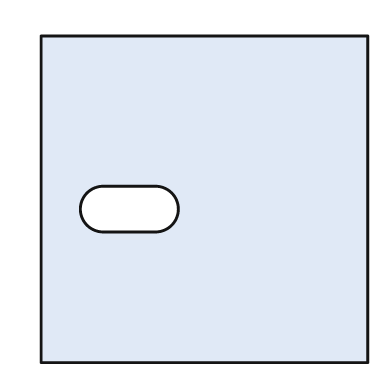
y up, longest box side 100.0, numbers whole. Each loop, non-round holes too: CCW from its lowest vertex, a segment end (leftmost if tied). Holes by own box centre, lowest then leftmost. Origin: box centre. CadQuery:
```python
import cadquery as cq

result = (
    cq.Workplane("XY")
    .moveTo(-50.0, -50.0)
    .lineTo(50.0, -50.0)
    .lineTo(50.0, 50.0)
    .lineTo(-50.0, 50.0)
    .close()
    .moveTo(-31.0, -10.0)
    .lineTo(-15.0, -10.0)
    .threePointArc((-8.0, -3.0), (-15.0, 4.0))
    .lineTo(-31.0, 4.0)
    .threePointArc((-38.0, -3.0), (-31.0, -10.0))
    .close()
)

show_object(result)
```